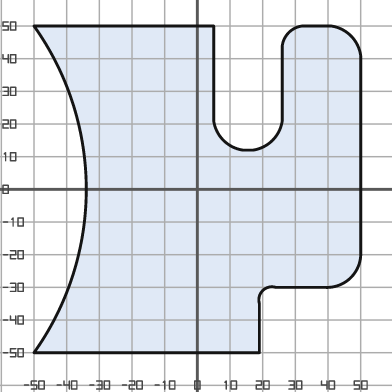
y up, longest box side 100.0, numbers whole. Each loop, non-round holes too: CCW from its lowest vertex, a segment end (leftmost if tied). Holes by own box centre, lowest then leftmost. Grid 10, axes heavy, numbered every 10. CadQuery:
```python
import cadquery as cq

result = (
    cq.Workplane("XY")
    .moveTo(-50.0, -50.0)
    .lineTo(19.0, -50.0)
    .lineTo(19.0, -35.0)
    .threePointArc((20.0, -31.0), (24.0, -30.0))
    .lineTo(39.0, -30.0)
    .threePointArc((47.0, -27.0), (50.0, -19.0))
    .lineTo(50.0, 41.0)
    .threePointArc((47.0, 47.0), (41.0, 50.0))
    .lineTo(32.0, 50.0)
    .threePointArc((28.0, 48.0), (26.0, 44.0))
    .lineTo(26.0, 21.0)
    .threePointArc((23.0, 15.0), (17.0, 12.0))
    .lineTo(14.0, 12.0)
    .threePointArc((8.0, 15.0), (5.0, 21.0))
    .lineTo(5.0, 50.0)
    .lineTo(-50.0, 50.0)
    .threePointArc((-34.0, 0.0), (-50.0, -50.0))
    .close()
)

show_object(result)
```